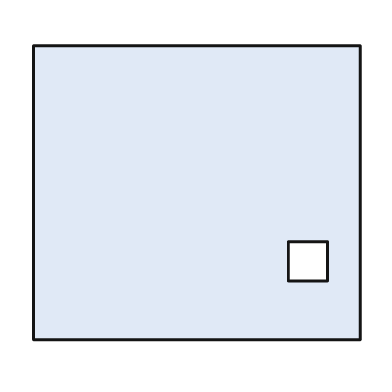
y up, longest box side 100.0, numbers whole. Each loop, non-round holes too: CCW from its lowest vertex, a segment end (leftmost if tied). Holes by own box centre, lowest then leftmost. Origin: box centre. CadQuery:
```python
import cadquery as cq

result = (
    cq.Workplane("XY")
    .moveTo(-50.0, -45.0)
    .lineTo(50.0, -45.0)
    .lineTo(50.0, 45.0)
    .lineTo(-50.0, 45.0)
    .close()
    .moveTo(28.0, -27.0)
    .lineTo(40.0, -27.0)
    .lineTo(40.0, -15.0)
    .lineTo(28.0, -15.0)
    .close()
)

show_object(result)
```